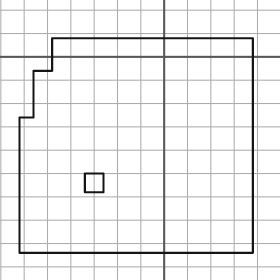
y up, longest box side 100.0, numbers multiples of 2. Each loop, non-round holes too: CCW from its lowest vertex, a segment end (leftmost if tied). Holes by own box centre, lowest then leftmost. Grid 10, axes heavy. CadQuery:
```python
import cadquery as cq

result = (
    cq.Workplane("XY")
    .moveTo(-62.0, -84.0)
    .lineTo(38.0, -84.0)
    .lineTo(38.0, 8.0)
    .lineTo(-48.0, 8.0)
    .lineTo(-48.0, -6.0)
    .lineTo(-56.0, -6.0)
    .lineTo(-56.0, -26.0)
    .lineTo(-62.0, -26.0)
    .close()
    .moveTo(-34.0, -58.0)
    .lineTo(-26.0, -58.0)
    .lineTo(-26.0, -50.0)
    .lineTo(-34.0, -50.0)
    .close()
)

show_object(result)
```